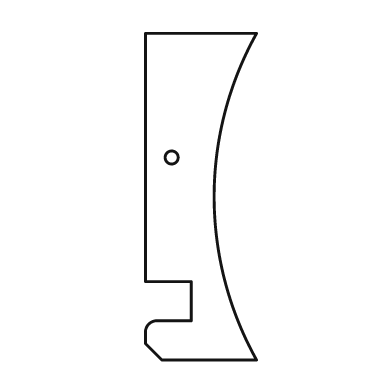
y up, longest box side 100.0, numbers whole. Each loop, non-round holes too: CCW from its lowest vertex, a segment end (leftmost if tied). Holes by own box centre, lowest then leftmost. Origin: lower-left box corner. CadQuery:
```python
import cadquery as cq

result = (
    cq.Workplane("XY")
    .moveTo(5.0, 0.0)
    .lineTo(34.0, 0.0)
    .threePointArc((21.0, 50.0), (34.0, 100.0))
    .lineTo(0.0, 100.0)
    .lineTo(0.0, 24.0)
    .lineTo(14.0, 24.0)
    .lineTo(14.0, 12.0)
    .lineTo(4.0, 12.0)
    .threePointArc((1.0, 11.0), (0.0, 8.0))
    .lineTo(0.0, 5.0)
    .close()
    .moveTo(8.0, 62.0)
    .circle(2.0)
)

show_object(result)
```